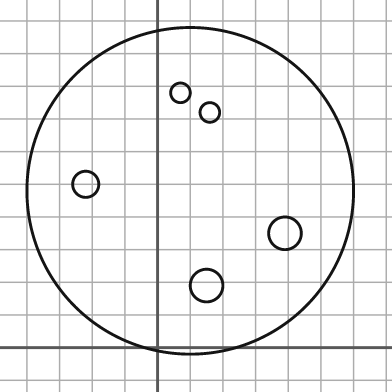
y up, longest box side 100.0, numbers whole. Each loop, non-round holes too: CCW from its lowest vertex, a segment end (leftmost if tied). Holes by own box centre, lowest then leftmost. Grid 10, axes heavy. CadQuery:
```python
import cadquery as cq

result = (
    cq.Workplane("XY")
    .moveTo(10.0, 48.0)
    .circle(50.0)
    .moveTo(15.0, 19.0)
    .circle(5.0)
    .moveTo(39.0, 35.0)
    .circle(5.0)
    .moveTo(-22.0, 50.0)
    .circle(4.0)
    .moveTo(16.0, 72.0)
    .circle(3.0)
    .moveTo(7.0, 78.0)
    .circle(3.0)
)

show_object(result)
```